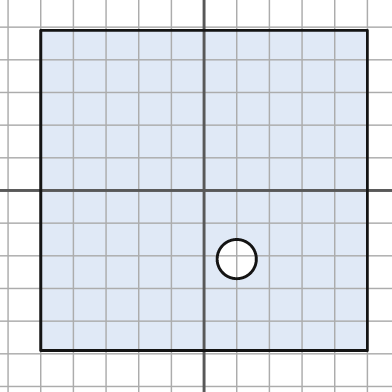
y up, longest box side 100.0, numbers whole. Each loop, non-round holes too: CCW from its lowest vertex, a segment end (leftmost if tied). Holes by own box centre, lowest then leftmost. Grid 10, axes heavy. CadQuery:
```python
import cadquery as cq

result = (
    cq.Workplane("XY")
    .moveTo(-50.0, -49.0)
    .lineTo(50.0, -49.0)
    .lineTo(50.0, 49.0)
    .lineTo(-50.0, 49.0)
    .close()
    .moveTo(10.0, -21.0)
    .circle(6.0)
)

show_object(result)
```